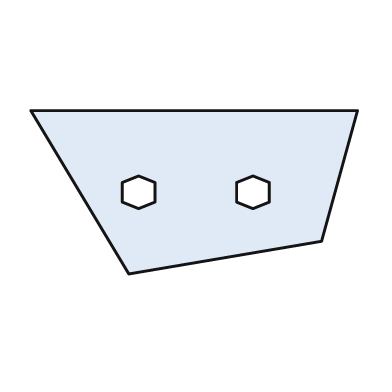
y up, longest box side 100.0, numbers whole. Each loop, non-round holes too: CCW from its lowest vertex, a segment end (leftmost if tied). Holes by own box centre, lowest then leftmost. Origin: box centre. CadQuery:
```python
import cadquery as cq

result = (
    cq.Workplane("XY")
    .moveTo(-20.0, -25.0)
    .lineTo(39.0, -15.0)
    .lineTo(50.0, 25.0)
    .lineTo(-50.0, 25.0)
    .close()
    .moveTo(-17.0, -5.0)
    .lineTo(-12.0, -3.0)
    .lineTo(-12.0, 3.0)
    .lineTo(-17.0, 5.0)
    .lineTo(-22.0, 3.0)
    .lineTo(-22.0, -3.0)
    .close()
    .moveTo(18.0, -5.0)
    .lineTo(23.0, -3.0)
    .lineTo(23.0, 3.0)
    .lineTo(18.0, 5.0)
    .lineTo(13.0, 3.0)
    .lineTo(13.0, -3.0)
    .close()
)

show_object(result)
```